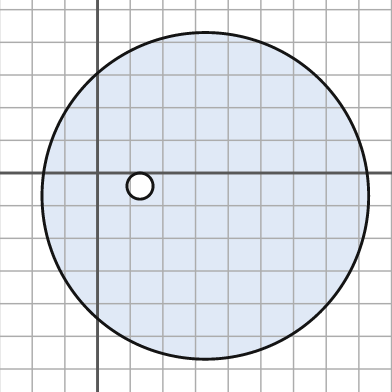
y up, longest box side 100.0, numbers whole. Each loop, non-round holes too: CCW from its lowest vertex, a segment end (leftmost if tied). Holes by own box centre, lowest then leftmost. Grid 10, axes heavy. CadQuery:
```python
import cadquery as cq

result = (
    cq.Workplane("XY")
    .moveTo(33.0, -7.0)
    .circle(50.0)
    .moveTo(13.0, -4.0)
    .circle(4.0)
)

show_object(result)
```